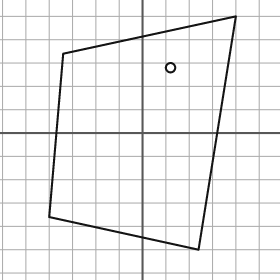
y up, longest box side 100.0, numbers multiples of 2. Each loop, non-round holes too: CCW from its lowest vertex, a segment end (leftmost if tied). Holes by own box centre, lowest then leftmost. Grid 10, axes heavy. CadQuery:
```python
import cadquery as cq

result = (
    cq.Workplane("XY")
    .moveTo(24.0, -50.0)
    .lineTo(40.0, 50.0)
    .lineTo(-34.0, 34.0)
    .lineTo(-40.0, -36.0)
    .close()
    .moveTo(12.0, 28.0)
    .circle(2.0)
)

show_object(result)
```